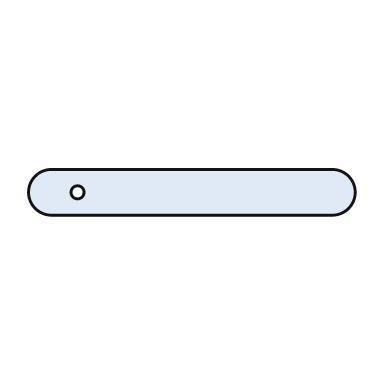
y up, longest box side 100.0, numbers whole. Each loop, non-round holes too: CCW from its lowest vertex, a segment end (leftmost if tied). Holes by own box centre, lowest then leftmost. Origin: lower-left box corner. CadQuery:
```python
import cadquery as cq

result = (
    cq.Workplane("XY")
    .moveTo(7.0, 0.0)
    .lineTo(93.0, 0.0)
    .threePointArc((100.0, 7.0), (93.0, 14.0))
    .lineTo(7.0, 14.0)
    .threePointArc((0.0, 7.0), (7.0, 0.0))
    .close()
    .moveTo(15.0, 7.0)
    .circle(2.0)
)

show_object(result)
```